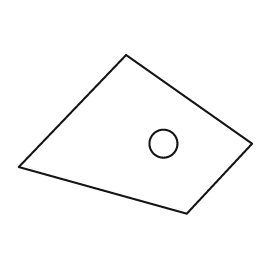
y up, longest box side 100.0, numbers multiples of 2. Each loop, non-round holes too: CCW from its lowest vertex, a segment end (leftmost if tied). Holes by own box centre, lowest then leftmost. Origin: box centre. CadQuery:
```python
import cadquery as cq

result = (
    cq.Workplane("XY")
    .moveTo(22.0, -34.0)
    .lineTo(50.0, -4.0)
    .lineTo(-4.0, 34.0)
    .lineTo(-50.0, -14.0)
    .close()
    .moveTo(12.0, -4.0)
    .circle(6.0)
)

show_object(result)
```